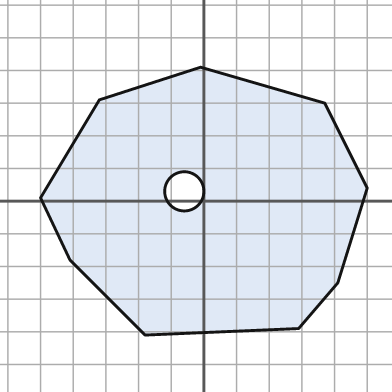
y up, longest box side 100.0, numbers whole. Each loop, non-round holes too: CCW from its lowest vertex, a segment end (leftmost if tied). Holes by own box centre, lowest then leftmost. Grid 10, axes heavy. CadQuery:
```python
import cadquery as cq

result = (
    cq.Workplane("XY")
    .moveTo(-18.0, -41.0)
    .lineTo(29.0, -39.0)
    .lineTo(41.0, -25.0)
    .lineTo(50.0, 4.0)
    .lineTo(37.0, 30.0)
    .lineTo(-1.0, 41.0)
    .lineTo(-32.0, 31.0)
    .lineTo(-50.0, 1.0)
    .lineTo(-41.0, -18.0)
    .close()
    .moveTo(-6.0, 3.0)
    .circle(6.0)
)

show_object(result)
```